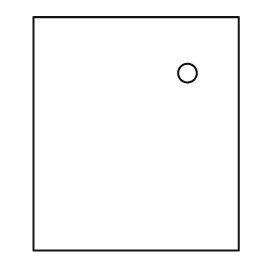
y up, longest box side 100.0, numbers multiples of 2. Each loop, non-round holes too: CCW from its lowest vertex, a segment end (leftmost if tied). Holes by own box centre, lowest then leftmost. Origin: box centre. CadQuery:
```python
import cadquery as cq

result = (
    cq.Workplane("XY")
    .moveTo(-44.0, -50.0)
    .lineTo(44.0, -50.0)
    .lineTo(44.0, 50.0)
    .lineTo(-44.0, 50.0)
    .close()
    .moveTo(22.0, 26.0)
    .circle(4.0)
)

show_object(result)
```